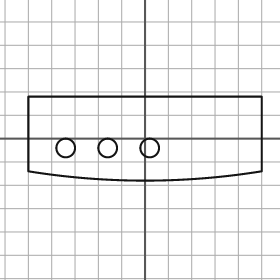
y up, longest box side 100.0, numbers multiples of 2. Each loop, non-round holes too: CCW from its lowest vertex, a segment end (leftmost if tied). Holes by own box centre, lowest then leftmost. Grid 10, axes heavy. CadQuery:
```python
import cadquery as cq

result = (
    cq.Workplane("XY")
    .moveTo(-50.0, -14.0)
    .threePointArc((0.0, -18.0), (50.0, -14.0))
    .lineTo(50.0, 18.0)
    .lineTo(-50.0, 18.0)
    .close()
    .moveTo(-34.0, -4.0)
    .circle(4.0)
    .moveTo(-16.0, -4.0)
    .circle(4.0)
    .moveTo(2.0, -4.0)
    .circle(4.0)
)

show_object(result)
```